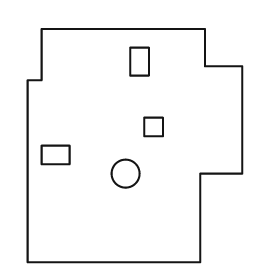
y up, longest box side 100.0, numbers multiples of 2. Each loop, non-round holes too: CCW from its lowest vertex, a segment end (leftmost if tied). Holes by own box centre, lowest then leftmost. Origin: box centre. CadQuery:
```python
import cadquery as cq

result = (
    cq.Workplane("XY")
    .moveTo(-46.0, -50.0)
    .lineTo(28.0, -50.0)
    .lineTo(28.0, -12.0)
    .lineTo(46.0, -12.0)
    .lineTo(46.0, 34.0)
    .lineTo(30.0, 34.0)
    .lineTo(30.0, 50.0)
    .lineTo(-40.0, 50.0)
    .lineTo(-40.0, 28.0)
    .lineTo(-46.0, 28.0)
    .close()
    .moveTo(-4.0, -12.0)
    .circle(6.0)
    .moveTo(-40.0, -8.0)
    .lineTo(-28.0, -8.0)
    .lineTo(-28.0, 0.0)
    .lineTo(-40.0, 0.0)
    .close()
    .moveTo(4.0, 4.0)
    .lineTo(12.0, 4.0)
    .lineTo(12.0, 12.0)
    .lineTo(4.0, 12.0)
    .close()
    .moveTo(-2.0, 30.0)
    .lineTo(6.0, 30.0)
    .lineTo(6.0, 42.0)
    .lineTo(-2.0, 42.0)
    .close()
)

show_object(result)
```